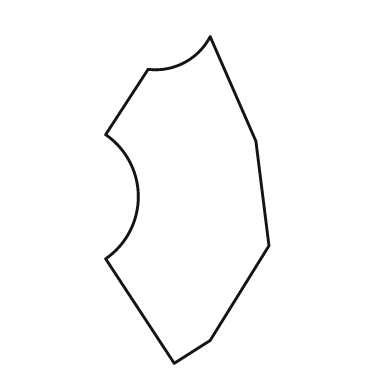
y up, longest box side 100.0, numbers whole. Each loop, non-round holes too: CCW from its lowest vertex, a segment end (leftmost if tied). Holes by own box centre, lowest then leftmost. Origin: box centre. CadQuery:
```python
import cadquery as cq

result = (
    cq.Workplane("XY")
    .moveTo(-4.0, -50.0)
    .lineTo(7.0, -43.0)
    .lineTo(25.0, -14.0)
    .lineTo(21.0, 18.0)
    .lineTo(7.0, 50.0)
    .threePointArc((-1.0, 42.0), (-12.0, 40.0))
    .lineTo(-25.0, 20.0)
    .threePointArc((-15.0, 1.0), (-25.0, -18.0))
    .close()
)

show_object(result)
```